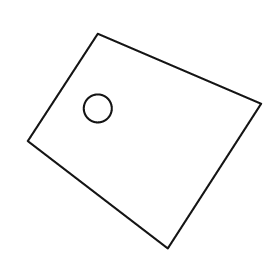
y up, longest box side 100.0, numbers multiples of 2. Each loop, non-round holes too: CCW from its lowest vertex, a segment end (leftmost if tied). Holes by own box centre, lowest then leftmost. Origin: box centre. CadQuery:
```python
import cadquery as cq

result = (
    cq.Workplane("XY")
    .moveTo(10.0, -46.0)
    .lineTo(50.0, 16.0)
    .lineTo(-20.0, 46.0)
    .lineTo(-50.0, 0.0)
    .close()
    .moveTo(-20.0, 14.0)
    .circle(6.0)
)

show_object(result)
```